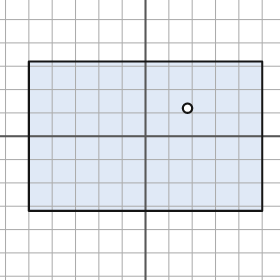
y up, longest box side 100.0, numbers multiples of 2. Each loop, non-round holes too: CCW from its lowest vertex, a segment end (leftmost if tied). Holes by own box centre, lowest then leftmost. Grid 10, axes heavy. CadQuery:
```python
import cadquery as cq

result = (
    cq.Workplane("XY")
    .moveTo(-50.0, -32.0)
    .lineTo(50.0, -32.0)
    .lineTo(50.0, 32.0)
    .lineTo(-50.0, 32.0)
    .close()
    .moveTo(18.0, 12.0)
    .circle(2.0)
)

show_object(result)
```